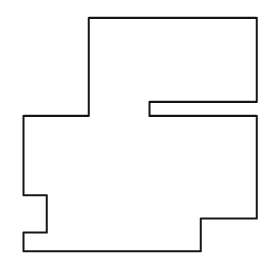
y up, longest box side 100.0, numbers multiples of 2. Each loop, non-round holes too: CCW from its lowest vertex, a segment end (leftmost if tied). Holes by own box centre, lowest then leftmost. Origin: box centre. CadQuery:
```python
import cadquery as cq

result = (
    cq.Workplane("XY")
    .moveTo(-50.0, -50.0)
    .lineTo(26.0, -50.0)
    .lineTo(26.0, -36.0)
    .lineTo(50.0, -36.0)
    .lineTo(50.0, 8.0)
    .lineTo(4.0, 8.0)
    .lineTo(4.0, 14.0)
    .lineTo(50.0, 14.0)
    .lineTo(50.0, 50.0)
    .lineTo(-22.0, 50.0)
    .lineTo(-22.0, 8.0)
    .lineTo(-50.0, 8.0)
    .lineTo(-50.0, -26.0)
    .lineTo(-40.0, -26.0)
    .lineTo(-40.0, -42.0)
    .lineTo(-50.0, -42.0)
    .close()
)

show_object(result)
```